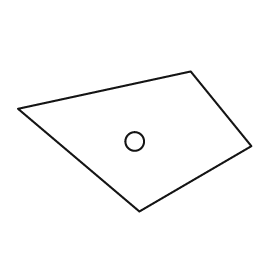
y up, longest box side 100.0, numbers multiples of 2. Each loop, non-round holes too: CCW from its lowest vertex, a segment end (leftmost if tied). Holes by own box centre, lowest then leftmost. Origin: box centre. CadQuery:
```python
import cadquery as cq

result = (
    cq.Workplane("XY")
    .moveTo(2.0, -30.0)
    .lineTo(50.0, -2.0)
    .lineTo(24.0, 30.0)
    .lineTo(-50.0, 14.0)
    .close()
    .moveTo(0.0, 0.0)
    .circle(4.0)
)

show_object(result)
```